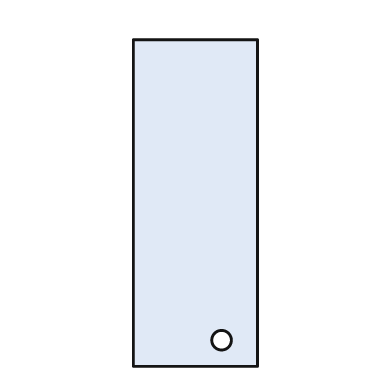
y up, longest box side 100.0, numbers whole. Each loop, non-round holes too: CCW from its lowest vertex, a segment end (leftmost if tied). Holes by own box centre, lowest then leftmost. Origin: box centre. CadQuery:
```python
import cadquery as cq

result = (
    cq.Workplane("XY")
    .moveTo(-19.0, -50.0)
    .lineTo(19.0, -50.0)
    .lineTo(19.0, 50.0)
    .lineTo(-19.0, 50.0)
    .close()
    .moveTo(8.0, -42.0)
    .circle(3.0)
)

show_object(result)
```